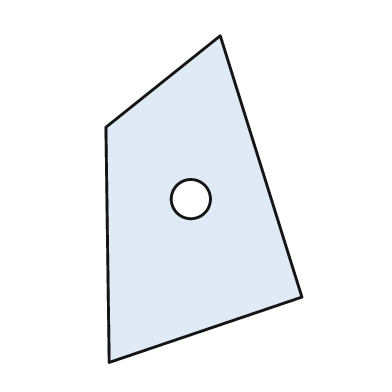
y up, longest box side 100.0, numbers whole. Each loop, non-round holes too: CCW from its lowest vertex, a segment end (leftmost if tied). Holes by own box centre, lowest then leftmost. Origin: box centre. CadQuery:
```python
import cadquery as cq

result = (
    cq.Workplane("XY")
    .moveTo(-29.0, -50.0)
    .lineTo(30.0, -30.0)
    .lineTo(5.0, 50.0)
    .lineTo(-30.0, 22.0)
    .close()
    .moveTo(-4.0, 0.0)
    .circle(6.0)
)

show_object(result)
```